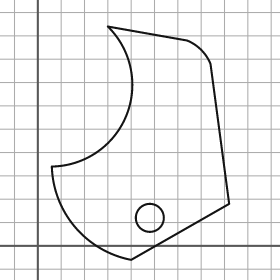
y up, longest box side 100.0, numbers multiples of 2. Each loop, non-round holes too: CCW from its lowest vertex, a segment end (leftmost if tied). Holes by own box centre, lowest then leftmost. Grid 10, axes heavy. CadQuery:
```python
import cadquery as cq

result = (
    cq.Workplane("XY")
    .moveTo(40.0, -6.0)
    .lineTo(82.0, 18.0)
    .lineTo(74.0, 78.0)
    .threePointArc((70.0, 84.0), (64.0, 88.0))
    .lineTo(30.0, 94.0)
    .threePointArc((38.0, 56.0), (6.0, 34.0))
    .threePointArc((16.0, 8.0), (40.0, -6.0))
    .close()
    .moveTo(48.0, 12.0)
    .circle(6.0)
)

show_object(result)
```